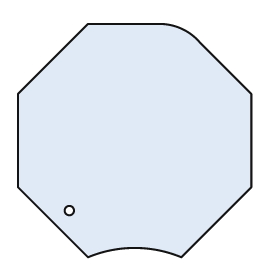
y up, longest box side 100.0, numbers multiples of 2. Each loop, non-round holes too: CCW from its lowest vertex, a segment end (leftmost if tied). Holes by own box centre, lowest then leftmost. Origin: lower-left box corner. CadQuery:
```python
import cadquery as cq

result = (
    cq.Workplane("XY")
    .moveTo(30.0, 0.0)
    .threePointArc((50.0, 4.0), (70.0, 0.0))
    .lineTo(100.0, 30.0)
    .lineTo(100.0, 70.0)
    .lineTo(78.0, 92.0)
    .threePointArc((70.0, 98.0), (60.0, 100.0))
    .lineTo(30.0, 100.0)
    .lineTo(0.0, 70.0)
    .lineTo(0.0, 30.0)
    .close()
    .moveTo(22.0, 20.0)
    .circle(2.0)
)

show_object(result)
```